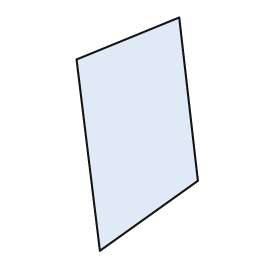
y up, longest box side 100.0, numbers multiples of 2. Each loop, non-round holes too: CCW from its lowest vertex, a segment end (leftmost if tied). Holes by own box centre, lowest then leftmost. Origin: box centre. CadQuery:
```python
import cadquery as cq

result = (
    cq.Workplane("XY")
    .moveTo(-16.0, -50.0)
    .lineTo(26.0, -20.0)
    .lineTo(18.0, 50.0)
    .lineTo(-26.0, 32.0)
    .close()
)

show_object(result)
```